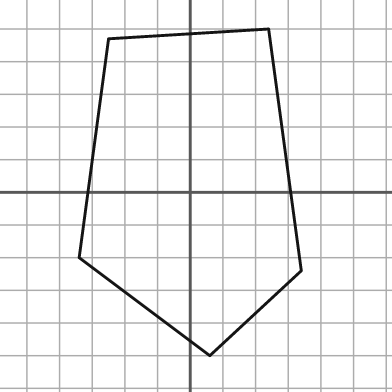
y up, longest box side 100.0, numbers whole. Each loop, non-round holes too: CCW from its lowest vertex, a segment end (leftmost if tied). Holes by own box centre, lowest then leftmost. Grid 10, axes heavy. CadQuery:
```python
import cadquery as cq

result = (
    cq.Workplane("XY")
    .moveTo(6.0, -50.0)
    .lineTo(34.0, -24.0)
    .lineTo(24.0, 50.0)
    .lineTo(-25.0, 47.0)
    .lineTo(-34.0, -20.0)
    .close()
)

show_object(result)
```